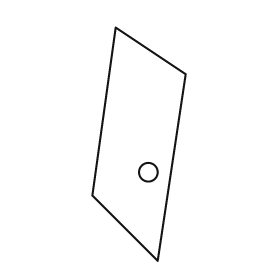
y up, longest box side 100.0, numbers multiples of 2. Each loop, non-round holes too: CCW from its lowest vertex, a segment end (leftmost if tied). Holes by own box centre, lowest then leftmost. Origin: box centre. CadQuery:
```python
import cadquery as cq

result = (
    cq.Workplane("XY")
    .moveTo(8.0, -50.0)
    .lineTo(20.0, 30.0)
    .lineTo(-10.0, 50.0)
    .lineTo(-20.0, -22.0)
    .close()
    .moveTo(4.0, -12.0)
    .circle(4.0)
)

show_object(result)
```